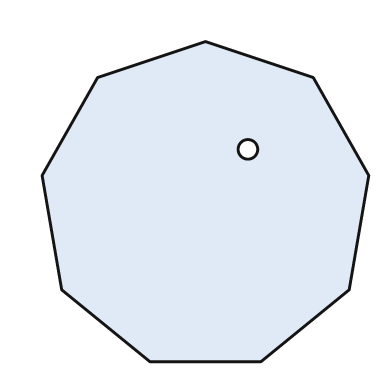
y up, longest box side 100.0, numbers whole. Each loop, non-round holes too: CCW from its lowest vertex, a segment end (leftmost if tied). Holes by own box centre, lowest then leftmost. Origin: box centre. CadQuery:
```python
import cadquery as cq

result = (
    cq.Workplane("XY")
    .moveTo(-17.0, -49.0)
    .lineTo(17.0, -49.0)
    .lineTo(44.0, -27.0)
    .lineTo(50.0, 8.0)
    .lineTo(33.0, 38.0)
    .lineTo(0.0, 49.0)
    .lineTo(-33.0, 38.0)
    .lineTo(-50.0, 8.0)
    .lineTo(-44.0, -27.0)
    .close()
    .moveTo(13.0, 16.0)
    .circle(3.0)
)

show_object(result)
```